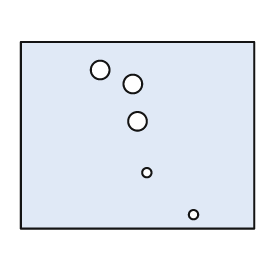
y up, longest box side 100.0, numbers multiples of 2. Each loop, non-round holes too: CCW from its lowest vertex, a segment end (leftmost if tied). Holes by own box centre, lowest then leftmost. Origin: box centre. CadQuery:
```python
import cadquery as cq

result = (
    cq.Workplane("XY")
    .moveTo(-50.0, -40.0)
    .lineTo(50.0, -40.0)
    .lineTo(50.0, 40.0)
    .lineTo(-50.0, 40.0)
    .close()
    .moveTo(24.0, -34.0)
    .circle(2.0)
    .moveTo(4.0, -16.0)
    .circle(2.0)
    .moveTo(0.0, 6.0)
    .circle(4.0)
    .moveTo(-2.0, 22.0)
    .circle(4.0)
    .moveTo(-16.0, 28.0)
    .circle(4.0)
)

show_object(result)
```